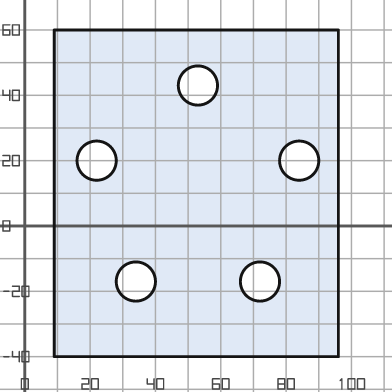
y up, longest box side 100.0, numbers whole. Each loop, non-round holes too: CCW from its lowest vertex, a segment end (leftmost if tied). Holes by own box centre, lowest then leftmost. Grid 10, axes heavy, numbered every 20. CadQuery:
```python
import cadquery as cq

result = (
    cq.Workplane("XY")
    .moveTo(9.0, -40.0)
    .lineTo(96.0, -40.0)
    .lineTo(96.0, 60.0)
    .lineTo(9.0, 60.0)
    .close()
    .moveTo(34.0, -17.0)
    .circle(6.0)
    .moveTo(72.0, -17.0)
    .circle(6.0)
    .moveTo(22.0, 20.0)
    .circle(6.0)
    .moveTo(84.0, 20.0)
    .circle(6.0)
    .moveTo(53.0, 43.0)
    .circle(6.0)
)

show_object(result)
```